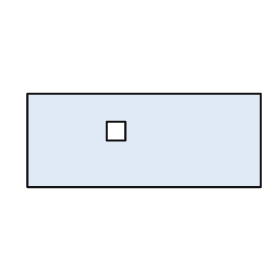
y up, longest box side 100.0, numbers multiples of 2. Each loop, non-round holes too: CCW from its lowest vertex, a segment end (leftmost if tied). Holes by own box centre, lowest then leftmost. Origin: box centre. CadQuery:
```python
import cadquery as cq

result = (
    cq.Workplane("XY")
    .moveTo(-50.0, -20.0)
    .lineTo(50.0, -20.0)
    .lineTo(50.0, 20.0)
    .lineTo(-50.0, 20.0)
    .close()
    .moveTo(-16.0, 0.0)
    .lineTo(-8.0, 0.0)
    .lineTo(-8.0, 8.0)
    .lineTo(-16.0, 8.0)
    .close()
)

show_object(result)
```